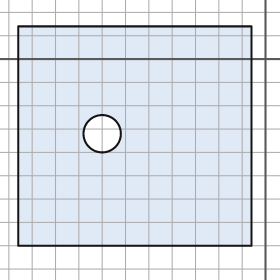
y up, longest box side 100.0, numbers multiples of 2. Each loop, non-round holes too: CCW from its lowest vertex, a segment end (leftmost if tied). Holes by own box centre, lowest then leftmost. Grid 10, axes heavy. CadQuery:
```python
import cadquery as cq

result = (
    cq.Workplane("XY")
    .moveTo(-106.0, -80.0)
    .lineTo(-6.0, -80.0)
    .lineTo(-6.0, 14.0)
    .lineTo(-106.0, 14.0)
    .close()
    .moveTo(-70.0, -32.0)
    .circle(8.0)
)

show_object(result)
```